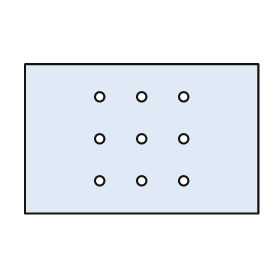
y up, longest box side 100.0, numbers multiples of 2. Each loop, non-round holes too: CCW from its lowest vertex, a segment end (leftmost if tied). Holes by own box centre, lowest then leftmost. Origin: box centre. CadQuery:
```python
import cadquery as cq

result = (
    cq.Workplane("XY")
    .moveTo(-50.0, -32.0)
    .lineTo(50.0, -32.0)
    .lineTo(50.0, 32.0)
    .lineTo(-50.0, 32.0)
    .close()
    .moveTo(-18.0, -18.0)
    .circle(2.0)
    .moveTo(0.0, -18.0)
    .circle(2.0)
    .moveTo(18.0, -18.0)
    .circle(2.0)
    .moveTo(-18.0, 0.0)
    .circle(2.0)
    .moveTo(0.0, 0.0)
    .circle(2.0)
    .moveTo(18.0, 0.0)
    .circle(2.0)
    .moveTo(-18.0, 18.0)
    .circle(2.0)
    .moveTo(0.0, 18.0)
    .circle(2.0)
    .moveTo(18.0, 18.0)
    .circle(2.0)
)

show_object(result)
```